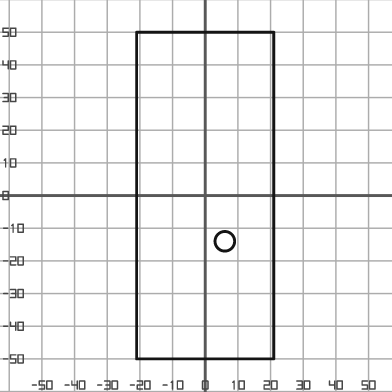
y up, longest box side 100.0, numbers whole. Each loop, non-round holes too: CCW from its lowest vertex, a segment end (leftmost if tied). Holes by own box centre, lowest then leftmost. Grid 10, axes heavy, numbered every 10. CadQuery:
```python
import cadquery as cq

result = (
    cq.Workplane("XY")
    .moveTo(-21.0, -50.0)
    .lineTo(21.0, -50.0)
    .lineTo(21.0, 50.0)
    .lineTo(-21.0, 50.0)
    .close()
    .moveTo(6.0, -14.0)
    .circle(3.0)
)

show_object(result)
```